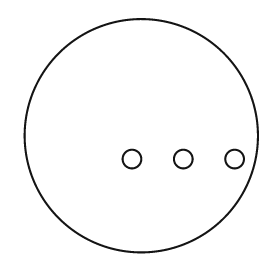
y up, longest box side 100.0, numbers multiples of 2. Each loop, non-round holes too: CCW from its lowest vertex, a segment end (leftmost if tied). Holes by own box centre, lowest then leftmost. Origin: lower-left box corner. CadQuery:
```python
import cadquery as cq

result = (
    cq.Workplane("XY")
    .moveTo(50.0, 50.0)
    .circle(50.0)
    .moveTo(46.0, 40.0)
    .circle(4.0)
    .moveTo(68.0, 40.0)
    .circle(4.0)
    .moveTo(90.0, 40.0)
    .circle(4.0)
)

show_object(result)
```